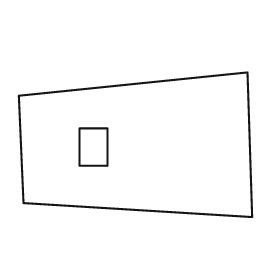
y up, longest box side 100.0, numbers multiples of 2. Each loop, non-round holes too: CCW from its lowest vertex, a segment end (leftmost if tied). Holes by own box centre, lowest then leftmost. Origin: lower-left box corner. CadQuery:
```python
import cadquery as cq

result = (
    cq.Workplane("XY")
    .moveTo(100.0, 0.0)
    .lineTo(98.0, 62.0)
    .lineTo(0.0, 52.0)
    .lineTo(2.0, 6.0)
    .close()
    .moveTo(26.0, 22.0)
    .lineTo(38.0, 22.0)
    .lineTo(38.0, 38.0)
    .lineTo(26.0, 38.0)
    .close()
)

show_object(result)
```